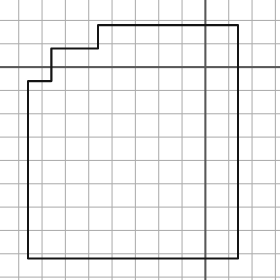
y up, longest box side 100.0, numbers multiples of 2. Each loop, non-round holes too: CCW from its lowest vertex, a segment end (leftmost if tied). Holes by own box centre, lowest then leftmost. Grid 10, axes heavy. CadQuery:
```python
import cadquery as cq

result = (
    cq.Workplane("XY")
    .moveTo(-76.0, -82.0)
    .lineTo(14.0, -82.0)
    .lineTo(14.0, 18.0)
    .lineTo(-46.0, 18.0)
    .lineTo(-46.0, 8.0)
    .lineTo(-66.0, 8.0)
    .lineTo(-66.0, -6.0)
    .lineTo(-76.0, -6.0)
    .close()
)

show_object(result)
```